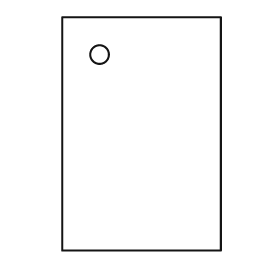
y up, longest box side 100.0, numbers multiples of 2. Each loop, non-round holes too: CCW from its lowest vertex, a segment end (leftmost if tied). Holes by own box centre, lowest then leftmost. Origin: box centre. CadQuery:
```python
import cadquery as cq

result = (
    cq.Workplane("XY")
    .moveTo(-34.0, -50.0)
    .lineTo(34.0, -50.0)
    .lineTo(34.0, 50.0)
    .lineTo(-34.0, 50.0)
    .close()
    .moveTo(-18.0, 34.0)
    .circle(4.0)
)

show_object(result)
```